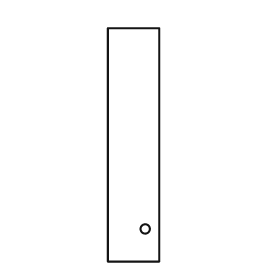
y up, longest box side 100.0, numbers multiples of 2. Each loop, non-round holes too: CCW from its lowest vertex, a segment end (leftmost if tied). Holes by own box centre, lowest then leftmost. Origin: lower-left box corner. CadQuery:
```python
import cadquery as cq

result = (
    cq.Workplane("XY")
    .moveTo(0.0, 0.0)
    .lineTo(22.0, 0.0)
    .lineTo(22.0, 100.0)
    .lineTo(0.0, 100.0)
    .close()
    .moveTo(16.0, 14.0)
    .circle(2.0)
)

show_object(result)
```